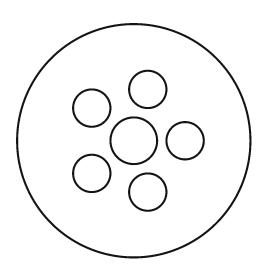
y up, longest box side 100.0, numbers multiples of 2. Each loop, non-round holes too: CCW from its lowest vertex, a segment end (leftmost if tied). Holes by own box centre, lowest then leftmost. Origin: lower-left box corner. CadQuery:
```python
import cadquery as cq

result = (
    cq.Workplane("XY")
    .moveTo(50.0, 50.0)
    .circle(50.0)
    .moveTo(56.0, 28.0)
    .circle(8.0)
    .moveTo(32.0, 36.0)
    .circle(8.0)
    .moveTo(50.0, 50.0)
    .circle(10.0)
    .moveTo(72.0, 50.0)
    .circle(8.0)
    .moveTo(32.0, 64.0)
    .circle(8.0)
    .moveTo(56.0, 72.0)
    .circle(8.0)
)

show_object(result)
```